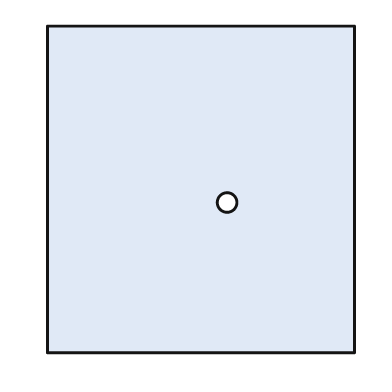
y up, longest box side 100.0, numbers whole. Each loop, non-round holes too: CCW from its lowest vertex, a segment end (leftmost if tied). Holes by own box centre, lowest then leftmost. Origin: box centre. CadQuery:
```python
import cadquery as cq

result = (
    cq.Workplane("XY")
    .moveTo(-47.0, -50.0)
    .lineTo(47.0, -50.0)
    .lineTo(47.0, 50.0)
    .lineTo(-47.0, 50.0)
    .close()
    .moveTo(8.0, -4.0)
    .circle(3.0)
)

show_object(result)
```